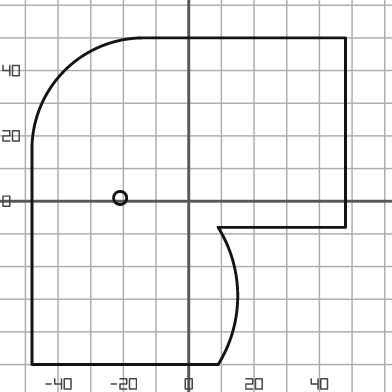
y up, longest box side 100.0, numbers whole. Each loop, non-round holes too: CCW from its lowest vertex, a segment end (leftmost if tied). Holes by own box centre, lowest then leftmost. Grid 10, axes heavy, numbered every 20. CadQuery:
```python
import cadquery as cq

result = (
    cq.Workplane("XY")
    .moveTo(-48.0, -50.0)
    .lineTo(9.0, -50.0)
    .threePointArc((15.0, -29.0), (9.0, -8.0))
    .lineTo(48.0, -8.0)
    .lineTo(48.0, 50.0)
    .lineTo(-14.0, 50.0)
    .threePointArc((-38.0, 40.0), (-48.0, 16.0))
    .close()
    .moveTo(-21.0, 1.0)
    .circle(2.0)
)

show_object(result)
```